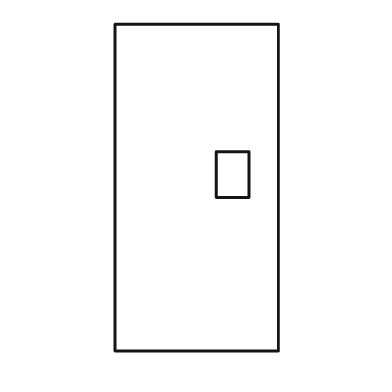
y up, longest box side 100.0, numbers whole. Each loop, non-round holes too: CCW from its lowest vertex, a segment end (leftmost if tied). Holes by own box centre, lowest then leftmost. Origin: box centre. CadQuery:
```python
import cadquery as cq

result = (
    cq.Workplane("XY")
    .moveTo(-25.0, -50.0)
    .lineTo(25.0, -50.0)
    .lineTo(25.0, 50.0)
    .lineTo(-25.0, 50.0)
    .close()
    .moveTo(6.0, -3.0)
    .lineTo(16.0, -3.0)
    .lineTo(16.0, 11.0)
    .lineTo(6.0, 11.0)
    .close()
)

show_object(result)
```